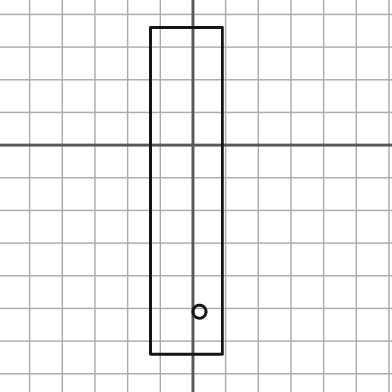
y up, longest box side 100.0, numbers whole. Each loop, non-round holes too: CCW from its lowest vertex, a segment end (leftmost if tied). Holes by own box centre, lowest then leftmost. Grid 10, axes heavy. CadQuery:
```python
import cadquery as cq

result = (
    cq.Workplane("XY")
    .moveTo(-13.0, -64.0)
    .lineTo(9.0, -64.0)
    .lineTo(9.0, 36.0)
    .lineTo(-13.0, 36.0)
    .close()
    .moveTo(2.0, -51.0)
    .circle(2.0)
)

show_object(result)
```